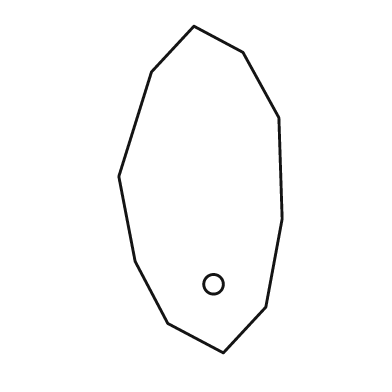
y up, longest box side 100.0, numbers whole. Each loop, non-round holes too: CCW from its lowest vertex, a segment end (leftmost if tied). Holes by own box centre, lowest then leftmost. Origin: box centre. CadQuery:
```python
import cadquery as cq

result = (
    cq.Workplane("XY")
    .moveTo(7.0, -50.0)
    .lineTo(20.0, -36.0)
    .lineTo(25.0, -9.0)
    .lineTo(24.0, 22.0)
    .lineTo(13.0, 42.0)
    .lineTo(-2.0, 50.0)
    .lineTo(-15.0, 36.0)
    .lineTo(-25.0, 4.0)
    .lineTo(-20.0, -22.0)
    .lineTo(-10.0, -41.0)
    .close()
    .moveTo(4.0, -29.0)
    .circle(3.0)
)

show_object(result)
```